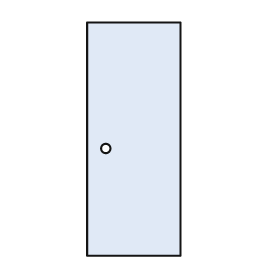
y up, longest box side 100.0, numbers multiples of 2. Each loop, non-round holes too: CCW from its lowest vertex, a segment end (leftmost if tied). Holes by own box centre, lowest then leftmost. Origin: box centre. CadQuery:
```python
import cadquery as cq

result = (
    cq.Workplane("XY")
    .moveTo(-20.0, -50.0)
    .lineTo(20.0, -50.0)
    .lineTo(20.0, 50.0)
    .lineTo(-20.0, 50.0)
    .close()
    .moveTo(-12.0, -4.0)
    .circle(2.0)
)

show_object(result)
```